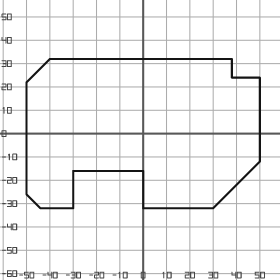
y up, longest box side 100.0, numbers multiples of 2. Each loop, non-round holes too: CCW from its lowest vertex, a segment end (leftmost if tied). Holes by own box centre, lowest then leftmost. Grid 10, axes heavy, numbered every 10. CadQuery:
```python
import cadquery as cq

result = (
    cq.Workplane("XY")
    .moveTo(-44.0, -32.0)
    .lineTo(-30.0, -32.0)
    .lineTo(-30.0, -16.0)
    .lineTo(0.0, -16.0)
    .lineTo(0.0, -32.0)
    .lineTo(30.0, -32.0)
    .lineTo(50.0, -12.0)
    .lineTo(50.0, 24.0)
    .lineTo(38.0, 24.0)
    .lineTo(38.0, 32.0)
    .lineTo(-40.0, 32.0)
    .lineTo(-50.0, 22.0)
    .lineTo(-50.0, -26.0)
    .close()
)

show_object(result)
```